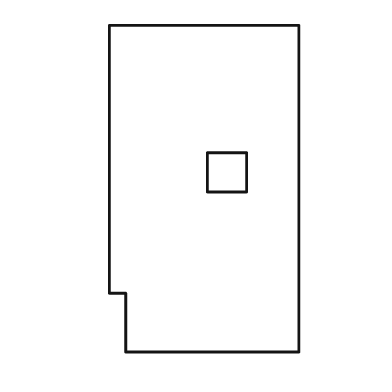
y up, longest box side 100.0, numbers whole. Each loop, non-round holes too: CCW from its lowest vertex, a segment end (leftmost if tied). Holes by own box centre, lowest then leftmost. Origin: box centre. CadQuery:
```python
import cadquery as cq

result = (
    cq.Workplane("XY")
    .moveTo(-24.0, -50.0)
    .lineTo(29.0, -50.0)
    .lineTo(29.0, 50.0)
    .lineTo(-29.0, 50.0)
    .lineTo(-29.0, -32.0)
    .lineTo(-24.0, -32.0)
    .close()
    .moveTo(1.0, -1.0)
    .lineTo(13.0, -1.0)
    .lineTo(13.0, 11.0)
    .lineTo(1.0, 11.0)
    .close()
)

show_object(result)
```